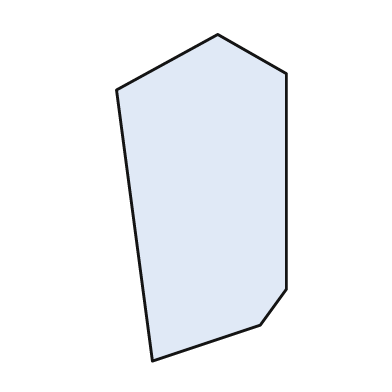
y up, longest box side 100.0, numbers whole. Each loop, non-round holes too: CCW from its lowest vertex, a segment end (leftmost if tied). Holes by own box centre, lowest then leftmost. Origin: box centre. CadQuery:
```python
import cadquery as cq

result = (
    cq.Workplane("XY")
    .moveTo(-15.0, -50.0)
    .lineTo(18.0, -39.0)
    .lineTo(26.0, -28.0)
    .lineTo(26.0, 38.0)
    .lineTo(5.0, 50.0)
    .lineTo(-26.0, 33.0)
    .close()
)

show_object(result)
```